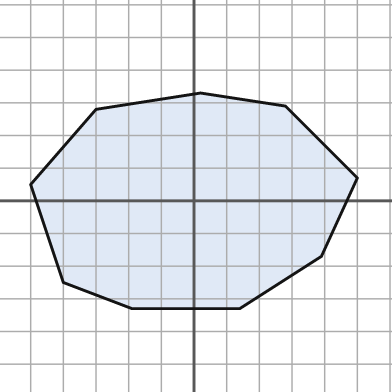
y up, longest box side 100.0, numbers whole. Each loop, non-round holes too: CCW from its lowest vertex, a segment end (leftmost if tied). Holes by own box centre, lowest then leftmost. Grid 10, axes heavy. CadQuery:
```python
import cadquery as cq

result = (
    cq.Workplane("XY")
    .moveTo(-19.0, -33.0)
    .lineTo(14.0, -33.0)
    .lineTo(39.0, -17.0)
    .lineTo(50.0, 7.0)
    .lineTo(28.0, 29.0)
    .lineTo(2.0, 33.0)
    .lineTo(-30.0, 28.0)
    .lineTo(-50.0, 5.0)
    .lineTo(-40.0, -25.0)
    .close()
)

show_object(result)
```